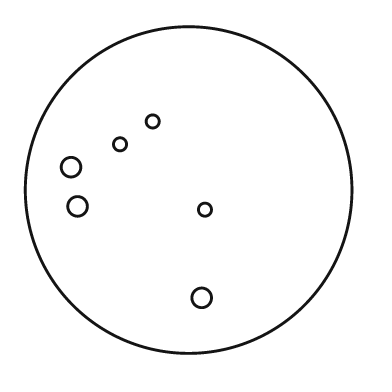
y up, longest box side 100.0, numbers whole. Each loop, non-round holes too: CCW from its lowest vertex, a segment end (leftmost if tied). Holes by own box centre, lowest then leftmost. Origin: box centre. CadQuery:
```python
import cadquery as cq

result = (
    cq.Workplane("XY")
    .moveTo(0.0, 0.0)
    .circle(50.0)
    .moveTo(4.0, -33.0)
    .circle(3.0)
    .moveTo(5.0, -6.0)
    .circle(2.0)
    .moveTo(-34.0, -5.0)
    .circle(3.0)
    .moveTo(-36.0, 7.0)
    .circle(3.0)
    .moveTo(-21.0, 14.0)
    .circle(2.0)
    .moveTo(-11.0, 21.0)
    .circle(2.0)
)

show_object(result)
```